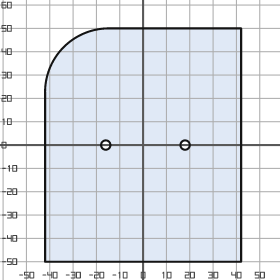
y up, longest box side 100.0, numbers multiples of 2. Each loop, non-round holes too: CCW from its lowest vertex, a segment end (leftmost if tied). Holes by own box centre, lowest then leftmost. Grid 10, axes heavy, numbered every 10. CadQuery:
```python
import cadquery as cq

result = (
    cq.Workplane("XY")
    .moveTo(-42.0, -50.0)
    .lineTo(42.0, -50.0)
    .lineTo(42.0, 50.0)
    .lineTo(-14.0, 50.0)
    .threePointArc((-34.0, 42.0), (-42.0, 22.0))
    .close()
    .moveTo(-16.0, 0.0)
    .circle(2.0)
    .moveTo(18.0, 0.0)
    .circle(2.0)
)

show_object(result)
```